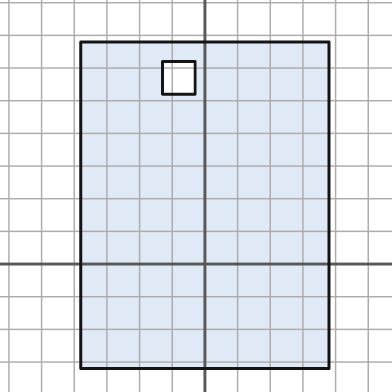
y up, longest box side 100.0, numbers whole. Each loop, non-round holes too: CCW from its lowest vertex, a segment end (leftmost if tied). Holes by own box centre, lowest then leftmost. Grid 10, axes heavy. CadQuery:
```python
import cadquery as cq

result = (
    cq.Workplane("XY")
    .moveTo(-38.0, -32.0)
    .lineTo(38.0, -32.0)
    .lineTo(38.0, 68.0)
    .lineTo(-38.0, 68.0)
    .close()
    .moveTo(-13.0, 52.0)
    .lineTo(-3.0, 52.0)
    .lineTo(-3.0, 62.0)
    .lineTo(-13.0, 62.0)
    .close()
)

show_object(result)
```